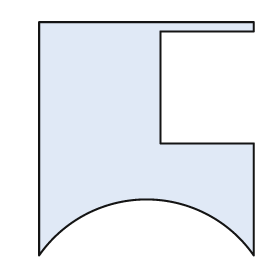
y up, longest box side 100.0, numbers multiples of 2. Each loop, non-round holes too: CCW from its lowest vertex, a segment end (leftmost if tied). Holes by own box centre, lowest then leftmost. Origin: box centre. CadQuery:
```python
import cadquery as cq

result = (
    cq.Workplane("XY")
    .moveTo(-46.0, -50.0)
    .threePointArc((0.0, -26.0), (46.0, -50.0))
    .lineTo(46.0, -2.0)
    .lineTo(6.0, -2.0)
    .lineTo(6.0, 46.0)
    .lineTo(46.0, 46.0)
    .lineTo(46.0, 50.0)
    .lineTo(-46.0, 50.0)
    .close()
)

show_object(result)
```